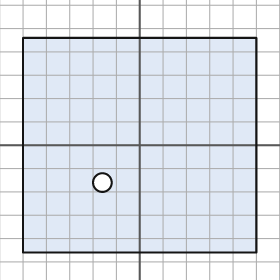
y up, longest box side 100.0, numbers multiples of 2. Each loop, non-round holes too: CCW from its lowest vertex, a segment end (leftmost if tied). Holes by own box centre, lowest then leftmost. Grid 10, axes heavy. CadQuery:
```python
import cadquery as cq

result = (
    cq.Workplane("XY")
    .moveTo(-50.0, -46.0)
    .lineTo(50.0, -46.0)
    .lineTo(50.0, 46.0)
    .lineTo(-50.0, 46.0)
    .close()
    .moveTo(-16.0, -16.0)
    .circle(4.0)
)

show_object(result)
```